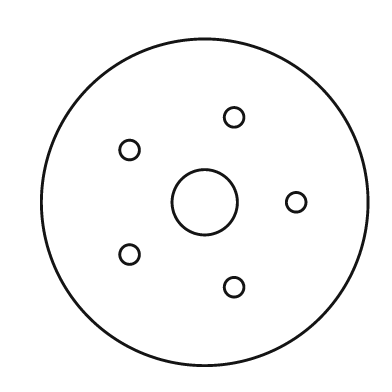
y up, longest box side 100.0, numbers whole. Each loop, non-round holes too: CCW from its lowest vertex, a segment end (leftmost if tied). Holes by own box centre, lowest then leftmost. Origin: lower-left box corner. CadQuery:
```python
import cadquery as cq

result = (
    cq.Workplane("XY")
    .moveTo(50.0, 50.0)
    .circle(50.0)
    .moveTo(59.0, 24.0)
    .circle(3.0)
    .moveTo(27.0, 34.0)
    .circle(3.0)
    .moveTo(50.0, 50.0)
    .circle(10.0)
    .moveTo(78.0, 50.0)
    .circle(3.0)
    .moveTo(27.0, 66.0)
    .circle(3.0)
    .moveTo(59.0, 76.0)
    .circle(3.0)
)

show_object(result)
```